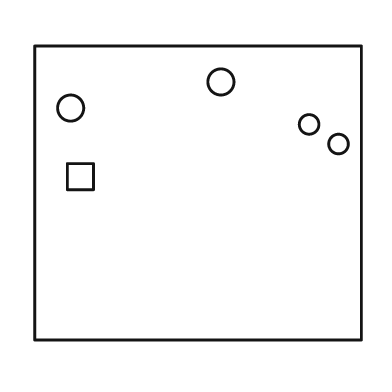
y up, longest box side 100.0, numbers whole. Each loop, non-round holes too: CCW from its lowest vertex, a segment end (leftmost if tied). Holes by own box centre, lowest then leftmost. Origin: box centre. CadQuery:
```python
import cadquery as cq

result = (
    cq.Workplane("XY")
    .moveTo(-50.0, -45.0)
    .lineTo(50.0, -45.0)
    .lineTo(50.0, 45.0)
    .lineTo(-50.0, 45.0)
    .close()
    .moveTo(-40.0, 1.0)
    .lineTo(-32.0, 1.0)
    .lineTo(-32.0, 9.0)
    .lineTo(-40.0, 9.0)
    .close()
    .moveTo(43.0, 15.0)
    .circle(3.0)
    .moveTo(34.0, 21.0)
    .circle(3.0)
    .moveTo(-39.0, 26.0)
    .circle(4.0)
    .moveTo(7.0, 34.0)
    .circle(4.0)
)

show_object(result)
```